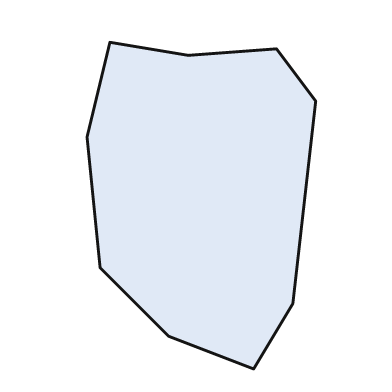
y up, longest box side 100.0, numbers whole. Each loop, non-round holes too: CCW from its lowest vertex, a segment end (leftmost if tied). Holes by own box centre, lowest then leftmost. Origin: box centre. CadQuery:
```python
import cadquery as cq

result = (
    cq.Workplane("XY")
    .moveTo(16.0, -50.0)
    .lineTo(28.0, -30.0)
    .lineTo(35.0, 32.0)
    .lineTo(23.0, 48.0)
    .lineTo(-4.0, 46.0)
    .lineTo(-28.0, 50.0)
    .lineTo(-35.0, 21.0)
    .lineTo(-31.0, -19.0)
    .lineTo(-10.0, -40.0)
    .close()
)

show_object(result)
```